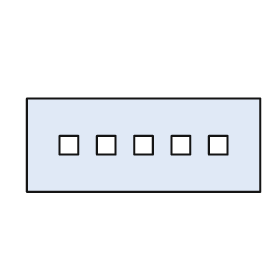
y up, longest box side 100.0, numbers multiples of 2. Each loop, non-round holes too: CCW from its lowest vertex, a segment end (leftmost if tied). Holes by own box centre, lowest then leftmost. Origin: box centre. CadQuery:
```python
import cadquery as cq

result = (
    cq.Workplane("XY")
    .moveTo(-50.0, -20.0)
    .lineTo(50.0, -20.0)
    .lineTo(50.0, 20.0)
    .lineTo(-50.0, 20.0)
    .close()
    .moveTo(-36.0, -4.0)
    .lineTo(-28.0, -4.0)
    .lineTo(-28.0, 4.0)
    .lineTo(-36.0, 4.0)
    .close()
    .moveTo(-20.0, -4.0)
    .lineTo(-12.0, -4.0)
    .lineTo(-12.0, 4.0)
    .lineTo(-20.0, 4.0)
    .close()
    .moveTo(-4.0, -4.0)
    .lineTo(4.0, -4.0)
    .lineTo(4.0, 4.0)
    .lineTo(-4.0, 4.0)
    .close()
    .moveTo(12.0, -4.0)
    .lineTo(20.0, -4.0)
    .lineTo(20.0, 4.0)
    .lineTo(12.0, 4.0)
    .close()
    .moveTo(28.0, -4.0)
    .lineTo(36.0, -4.0)
    .lineTo(36.0, 4.0)
    .lineTo(28.0, 4.0)
    .close()
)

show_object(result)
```